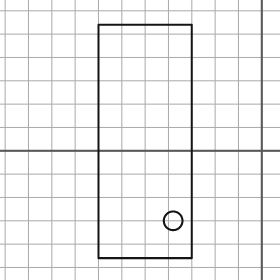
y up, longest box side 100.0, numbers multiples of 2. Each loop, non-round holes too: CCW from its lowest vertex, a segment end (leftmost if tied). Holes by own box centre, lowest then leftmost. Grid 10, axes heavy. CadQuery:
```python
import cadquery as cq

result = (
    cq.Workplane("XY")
    .moveTo(-70.0, -46.0)
    .lineTo(-30.0, -46.0)
    .lineTo(-30.0, 54.0)
    .lineTo(-70.0, 54.0)
    .close()
    .moveTo(-38.0, -30.0)
    .circle(4.0)
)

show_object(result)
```